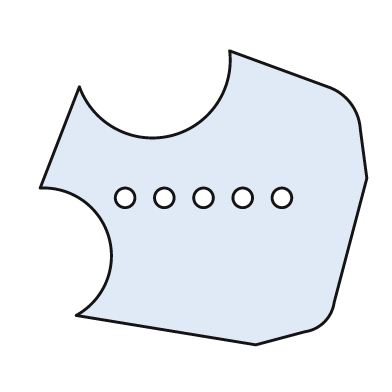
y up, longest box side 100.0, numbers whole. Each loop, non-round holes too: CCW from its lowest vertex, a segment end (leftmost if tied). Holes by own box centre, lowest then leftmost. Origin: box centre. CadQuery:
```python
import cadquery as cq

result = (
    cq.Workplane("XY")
    .moveTo(16.0, -45.0)
    .lineTo(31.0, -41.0)
    .threePointArc((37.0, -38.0), (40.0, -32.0))
    .lineTo(50.0, 6.0)
    .lineTo(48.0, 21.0)
    .threePointArc((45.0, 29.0), (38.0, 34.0))
    .lineTo(8.0, 45.0)
    .threePointArc((-10.0, 19.0), (-38.0, 34.0))
    .lineTo(-50.0, 3.0)
    .threePointArc((-29.0, -12.0), (-39.0, -36.0))
    .close()
    .moveTo(-24.0, 0.0)
    .circle(3.0)
    .moveTo(-12.0, 0.0)
    .circle(3.0)
    .moveTo(0.0, 0.0)
    .circle(3.0)
    .moveTo(12.0, 0.0)
    .circle(3.0)
    .moveTo(24.0, 0.0)
    .circle(3.0)
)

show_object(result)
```